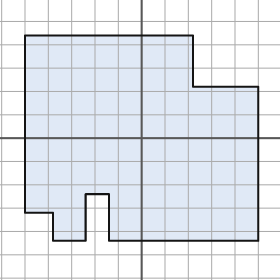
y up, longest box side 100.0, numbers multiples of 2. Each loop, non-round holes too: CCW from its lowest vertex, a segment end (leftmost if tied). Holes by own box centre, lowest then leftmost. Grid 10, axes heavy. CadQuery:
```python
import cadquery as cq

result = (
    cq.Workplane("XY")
    .moveTo(-38.0, -44.0)
    .lineTo(-24.0, -44.0)
    .lineTo(-24.0, -24.0)
    .lineTo(-14.0, -24.0)
    .lineTo(-14.0, -44.0)
    .lineTo(50.0, -44.0)
    .lineTo(50.0, 22.0)
    .lineTo(22.0, 22.0)
    .lineTo(22.0, 44.0)
    .lineTo(-50.0, 44.0)
    .lineTo(-50.0, -32.0)
    .lineTo(-38.0, -32.0)
    .close()
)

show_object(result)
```